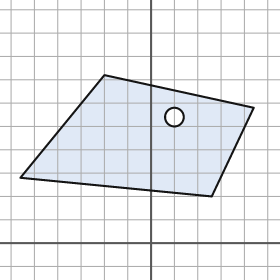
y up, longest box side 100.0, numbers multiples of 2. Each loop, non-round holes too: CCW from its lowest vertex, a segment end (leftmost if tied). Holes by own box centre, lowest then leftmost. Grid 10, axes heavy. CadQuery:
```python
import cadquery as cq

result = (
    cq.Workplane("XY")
    .moveTo(26.0, 20.0)
    .lineTo(44.0, 58.0)
    .lineTo(-20.0, 72.0)
    .lineTo(-56.0, 28.0)
    .close()
    .moveTo(10.0, 54.0)
    .circle(4.0)
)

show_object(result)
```